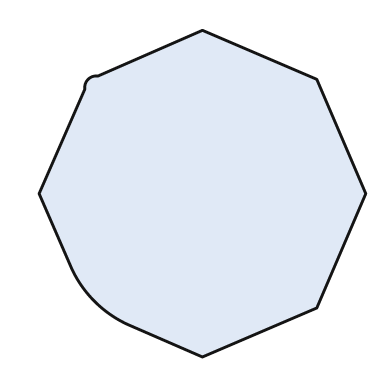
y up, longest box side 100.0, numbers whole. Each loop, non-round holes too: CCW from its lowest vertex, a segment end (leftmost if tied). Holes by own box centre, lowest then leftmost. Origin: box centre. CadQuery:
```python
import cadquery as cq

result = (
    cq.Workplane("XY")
    .moveTo(0.0, -50.0)
    .lineTo(35.0, -35.0)
    .lineTo(50.0, 0.0)
    .lineTo(35.0, 35.0)
    .lineTo(0.0, 50.0)
    .lineTo(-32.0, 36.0)
    .threePointArc((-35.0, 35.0), (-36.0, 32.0))
    .lineTo(-50.0, 0.0)
    .lineTo(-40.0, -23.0)
    .threePointArc((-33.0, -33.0), (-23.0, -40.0))
    .close()
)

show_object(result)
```